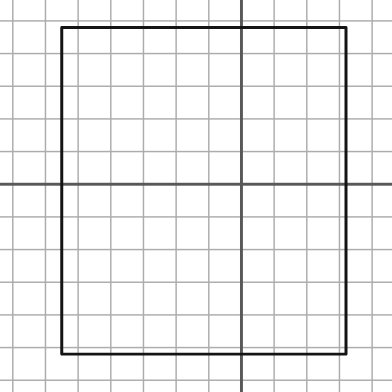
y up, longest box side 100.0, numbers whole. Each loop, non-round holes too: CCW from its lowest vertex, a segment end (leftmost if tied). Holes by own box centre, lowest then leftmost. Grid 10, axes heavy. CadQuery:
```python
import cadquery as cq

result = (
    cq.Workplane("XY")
    .moveTo(-55.0, -52.0)
    .lineTo(32.0, -52.0)
    .lineTo(32.0, 48.0)
    .lineTo(-55.0, 48.0)
    .close()
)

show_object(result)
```